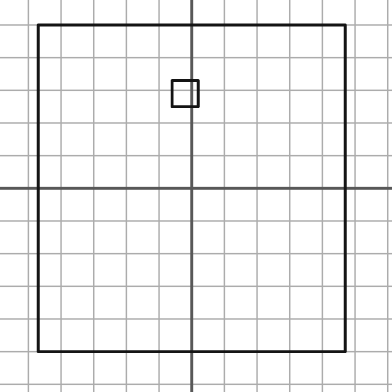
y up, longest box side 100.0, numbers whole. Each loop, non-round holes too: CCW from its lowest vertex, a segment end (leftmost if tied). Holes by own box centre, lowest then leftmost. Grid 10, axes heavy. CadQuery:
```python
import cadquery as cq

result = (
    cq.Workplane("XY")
    .moveTo(-47.0, -50.0)
    .lineTo(47.0, -50.0)
    .lineTo(47.0, 50.0)
    .lineTo(-47.0, 50.0)
    .close()
    .moveTo(-6.0, 25.0)
    .lineTo(2.0, 25.0)
    .lineTo(2.0, 33.0)
    .lineTo(-6.0, 33.0)
    .close()
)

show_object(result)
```